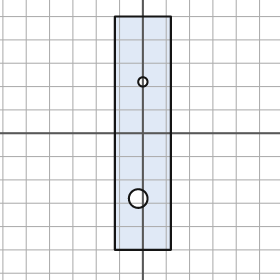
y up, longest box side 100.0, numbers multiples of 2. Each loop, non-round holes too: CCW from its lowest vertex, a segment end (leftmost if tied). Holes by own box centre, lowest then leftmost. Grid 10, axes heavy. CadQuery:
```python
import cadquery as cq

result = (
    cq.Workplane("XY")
    .moveTo(-12.0, -50.0)
    .lineTo(12.0, -50.0)
    .lineTo(12.0, 50.0)
    .lineTo(-12.0, 50.0)
    .close()
    .moveTo(-2.0, -28.0)
    .circle(4.0)
    .moveTo(0.0, 22.0)
    .circle(2.0)
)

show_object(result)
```